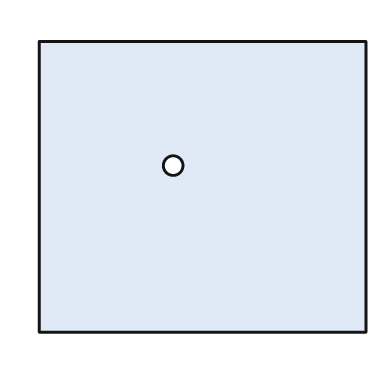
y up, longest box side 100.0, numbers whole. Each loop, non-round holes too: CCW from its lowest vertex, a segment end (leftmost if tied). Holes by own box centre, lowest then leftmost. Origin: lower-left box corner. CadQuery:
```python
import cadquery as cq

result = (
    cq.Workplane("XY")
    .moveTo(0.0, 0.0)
    .lineTo(100.0, 0.0)
    .lineTo(100.0, 89.0)
    .lineTo(0.0, 89.0)
    .close()
    .moveTo(41.0, 51.0)
    .circle(3.0)
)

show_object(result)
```